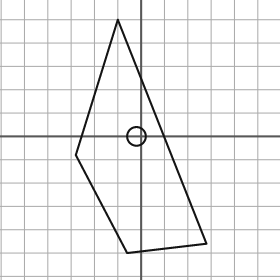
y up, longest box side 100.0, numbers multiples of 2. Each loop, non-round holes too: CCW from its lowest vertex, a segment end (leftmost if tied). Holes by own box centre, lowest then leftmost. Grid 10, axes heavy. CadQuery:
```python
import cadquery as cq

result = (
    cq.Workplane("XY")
    .moveTo(-6.0, -50.0)
    .lineTo(28.0, -46.0)
    .lineTo(-10.0, 50.0)
    .lineTo(-28.0, -8.0)
    .close()
    .moveTo(-2.0, 0.0)
    .circle(4.0)
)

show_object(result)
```